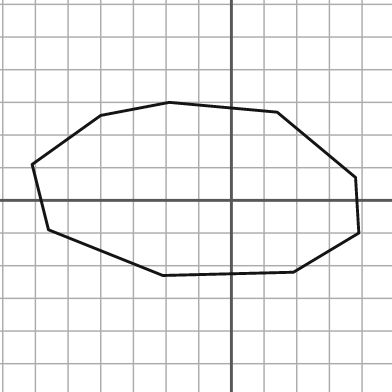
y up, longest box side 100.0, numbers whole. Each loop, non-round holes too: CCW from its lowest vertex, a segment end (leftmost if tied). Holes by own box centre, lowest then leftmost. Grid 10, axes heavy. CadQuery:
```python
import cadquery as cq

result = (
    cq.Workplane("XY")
    .moveTo(-21.0, -23.0)
    .lineTo(19.0, -22.0)
    .lineTo(39.0, -10.0)
    .lineTo(38.0, 7.0)
    .lineTo(14.0, 27.0)
    .lineTo(-19.0, 30.0)
    .lineTo(-40.0, 26.0)
    .lineTo(-61.0, 11.0)
    .lineTo(-56.0, -9.0)
    .close()
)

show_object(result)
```